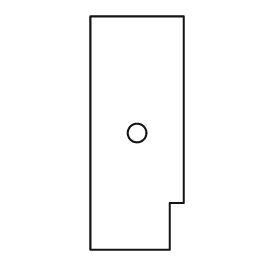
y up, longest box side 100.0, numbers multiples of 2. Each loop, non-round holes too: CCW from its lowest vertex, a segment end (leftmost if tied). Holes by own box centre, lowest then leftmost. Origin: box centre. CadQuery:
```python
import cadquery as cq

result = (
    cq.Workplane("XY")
    .moveTo(-20.0, -50.0)
    .lineTo(14.0, -50.0)
    .lineTo(14.0, -30.0)
    .lineTo(20.0, -30.0)
    .lineTo(20.0, 50.0)
    .lineTo(-20.0, 50.0)
    .close()
    .moveTo(0.0, 0.0)
    .circle(4.0)
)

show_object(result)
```